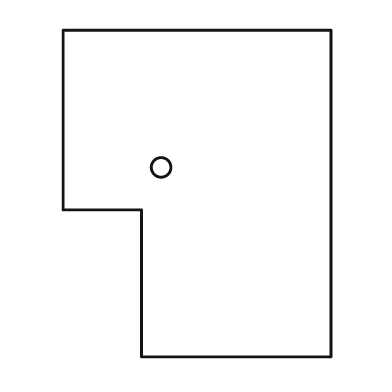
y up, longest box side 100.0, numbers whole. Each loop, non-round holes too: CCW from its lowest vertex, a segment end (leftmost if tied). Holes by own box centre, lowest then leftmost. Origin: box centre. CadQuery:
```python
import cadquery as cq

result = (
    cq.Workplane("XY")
    .moveTo(-17.0, -50.0)
    .lineTo(41.0, -50.0)
    .lineTo(41.0, 50.0)
    .lineTo(-41.0, 50.0)
    .lineTo(-41.0, -5.0)
    .lineTo(-17.0, -5.0)
    .close()
    .moveTo(-11.0, 8.0)
    .circle(3.0)
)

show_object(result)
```